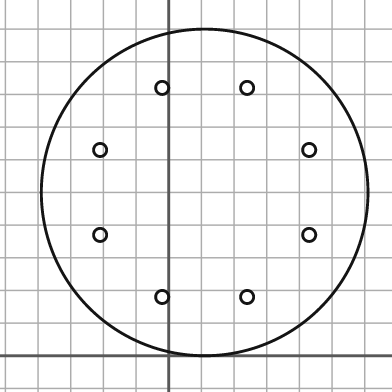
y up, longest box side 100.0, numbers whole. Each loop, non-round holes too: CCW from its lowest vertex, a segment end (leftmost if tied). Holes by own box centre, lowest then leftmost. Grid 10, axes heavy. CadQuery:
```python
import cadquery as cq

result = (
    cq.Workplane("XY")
    .moveTo(11.0, 50.0)
    .circle(50.0)
    .moveTo(-2.0, 18.0)
    .circle(2.0)
    .moveTo(24.0, 18.0)
    .circle(2.0)
    .moveTo(-21.0, 37.0)
    .circle(2.0)
    .moveTo(43.0, 37.0)
    .circle(2.0)
    .moveTo(-21.0, 63.0)
    .circle(2.0)
    .moveTo(43.0, 63.0)
    .circle(2.0)
    .moveTo(-2.0, 82.0)
    .circle(2.0)
    .moveTo(24.0, 82.0)
    .circle(2.0)
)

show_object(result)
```